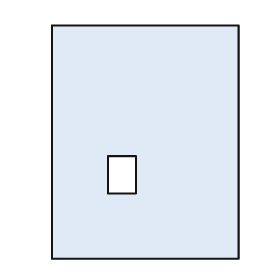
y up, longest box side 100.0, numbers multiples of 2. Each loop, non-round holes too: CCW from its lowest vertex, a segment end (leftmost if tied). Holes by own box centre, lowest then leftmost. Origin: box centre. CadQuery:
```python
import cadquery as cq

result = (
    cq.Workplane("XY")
    .moveTo(-40.0, -50.0)
    .lineTo(40.0, -50.0)
    .lineTo(40.0, 50.0)
    .lineTo(-40.0, 50.0)
    .close()
    .moveTo(-16.0, -22.0)
    .lineTo(-4.0, -22.0)
    .lineTo(-4.0, -6.0)
    .lineTo(-16.0, -6.0)
    .close()
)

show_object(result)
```